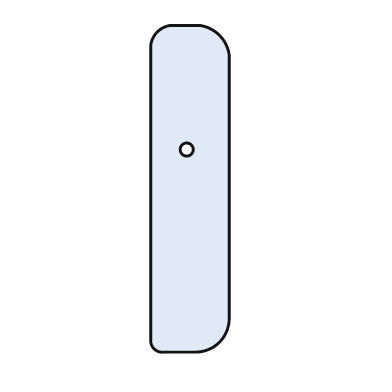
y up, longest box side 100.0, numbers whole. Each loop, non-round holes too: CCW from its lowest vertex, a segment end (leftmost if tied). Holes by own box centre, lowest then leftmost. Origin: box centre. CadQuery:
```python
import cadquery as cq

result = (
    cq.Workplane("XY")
    .moveTo(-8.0, -50.0)
    .lineTo(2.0, -50.0)
    .threePointArc((9.0, -47.0), (12.0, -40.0))
    .lineTo(12.0, 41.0)
    .threePointArc((9.0, 47.0), (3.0, 50.0))
    .lineTo(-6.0, 50.0)
    .threePointArc((-10.0, 48.0), (-12.0, 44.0))
    .lineTo(-12.0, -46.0)
    .threePointArc((-11.0, -49.0), (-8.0, -50.0))
    .close()
    .moveTo(-1.0, 12.0)
    .circle(2.0)
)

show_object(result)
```